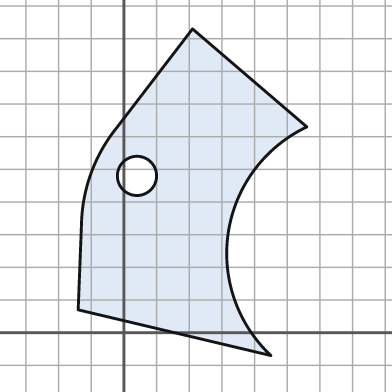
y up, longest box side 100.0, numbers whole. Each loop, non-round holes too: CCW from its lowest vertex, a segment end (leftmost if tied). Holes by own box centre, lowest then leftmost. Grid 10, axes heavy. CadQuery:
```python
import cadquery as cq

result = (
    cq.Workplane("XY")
    .moveTo(45.0, -7.0)
    .threePointArc((32.0, 31.0), (56.0, 63.0))
    .lineTo(21.0, 93.0)
    .lineTo(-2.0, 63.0)
    .threePointArc((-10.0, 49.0), (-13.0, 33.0))
    .lineTo(-14.0, 7.0)
    .close()
    .moveTo(4.0, 48.0)
    .circle(6.0)
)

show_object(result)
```